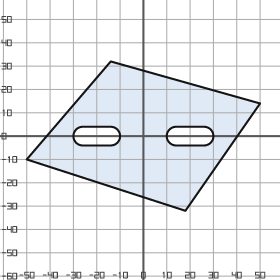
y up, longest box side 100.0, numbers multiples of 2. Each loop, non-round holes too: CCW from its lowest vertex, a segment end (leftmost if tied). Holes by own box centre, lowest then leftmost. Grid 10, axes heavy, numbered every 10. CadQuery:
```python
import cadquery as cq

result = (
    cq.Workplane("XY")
    .moveTo(18.0, -32.0)
    .lineTo(50.0, 14.0)
    .lineTo(-14.0, 32.0)
    .lineTo(-50.0, -10.0)
    .close()
    .moveTo(-26.0, -4.0)
    .lineTo(-14.0, -4.0)
    .threePointArc((-10.0, 0.0), (-14.0, 4.0))
    .lineTo(-26.0, 4.0)
    .threePointArc((-30.0, 0.0), (-26.0, -4.0))
    .close()
    .moveTo(14.0, -4.0)
    .lineTo(26.0, -4.0)
    .threePointArc((30.0, 0.0), (26.0, 4.0))
    .lineTo(14.0, 4.0)
    .threePointArc((10.0, 0.0), (14.0, -4.0))
    .close()
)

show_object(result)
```